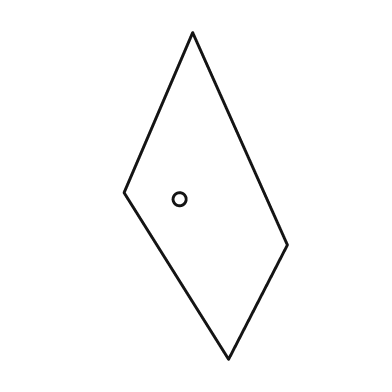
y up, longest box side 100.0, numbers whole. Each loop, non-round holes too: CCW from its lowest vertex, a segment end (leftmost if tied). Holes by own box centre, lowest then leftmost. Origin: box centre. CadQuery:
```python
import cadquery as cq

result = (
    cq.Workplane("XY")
    .moveTo(7.0, -50.0)
    .lineTo(25.0, -15.0)
    .lineTo(-4.0, 50.0)
    .lineTo(-25.0, 1.0)
    .close()
    .moveTo(-8.0, -1.0)
    .circle(2.0)
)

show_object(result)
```